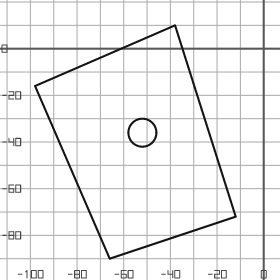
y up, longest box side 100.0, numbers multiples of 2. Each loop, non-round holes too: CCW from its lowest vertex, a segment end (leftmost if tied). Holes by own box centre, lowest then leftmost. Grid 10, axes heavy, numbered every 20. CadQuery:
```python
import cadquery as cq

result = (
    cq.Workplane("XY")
    .moveTo(-66.0, -90.0)
    .lineTo(-12.0, -72.0)
    .lineTo(-38.0, 10.0)
    .lineTo(-98.0, -16.0)
    .close()
    .moveTo(-52.0, -36.0)
    .circle(6.0)
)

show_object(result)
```